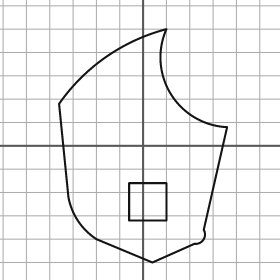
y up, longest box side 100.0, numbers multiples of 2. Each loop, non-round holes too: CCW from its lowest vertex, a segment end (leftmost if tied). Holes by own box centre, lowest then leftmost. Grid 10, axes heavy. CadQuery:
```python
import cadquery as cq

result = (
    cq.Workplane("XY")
    .moveTo(4.0, -50.0)
    .lineTo(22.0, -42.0)
    .threePointArc((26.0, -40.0), (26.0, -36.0))
    .lineTo(36.0, 8.0)
    .threePointArc((12.0, 22.0), (10.0, 50.0))
    .threePointArc((-16.0, 38.0), (-36.0, 18.0))
    .lineTo(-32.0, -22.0)
    .threePointArc((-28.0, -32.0), (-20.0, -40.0))
    .close()
    .moveTo(-6.0, -32.0)
    .lineTo(10.0, -32.0)
    .lineTo(10.0, -16.0)
    .lineTo(-6.0, -16.0)
    .close()
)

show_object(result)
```